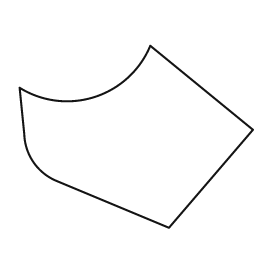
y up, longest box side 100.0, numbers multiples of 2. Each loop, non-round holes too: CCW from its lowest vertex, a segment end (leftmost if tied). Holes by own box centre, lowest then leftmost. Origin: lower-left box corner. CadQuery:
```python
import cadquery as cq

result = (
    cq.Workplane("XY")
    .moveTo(64.0, 0.0)
    .lineTo(100.0, 42.0)
    .lineTo(56.0, 78.0)
    .threePointArc((32.0, 56.0), (0.0, 60.0))
    .lineTo(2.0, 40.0)
    .threePointArc((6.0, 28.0), (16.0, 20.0))
    .close()
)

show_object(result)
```